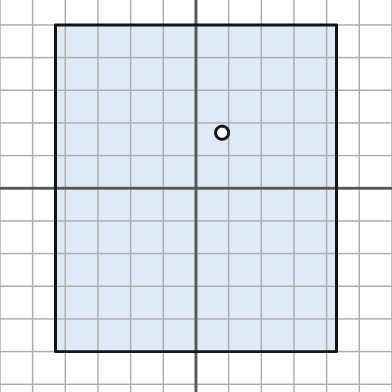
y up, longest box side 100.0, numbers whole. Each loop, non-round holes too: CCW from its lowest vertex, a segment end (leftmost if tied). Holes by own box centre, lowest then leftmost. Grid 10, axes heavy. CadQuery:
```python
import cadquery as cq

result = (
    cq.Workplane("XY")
    .moveTo(-43.0, -50.0)
    .lineTo(43.0, -50.0)
    .lineTo(43.0, 50.0)
    .lineTo(-43.0, 50.0)
    .close()
    .moveTo(8.0, 17.0)
    .circle(2.0)
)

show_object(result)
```